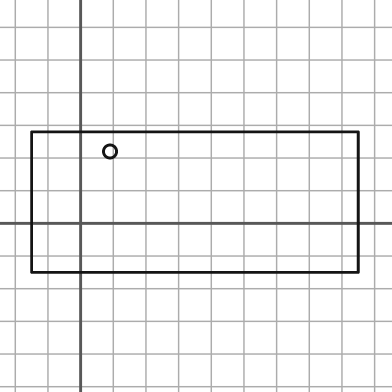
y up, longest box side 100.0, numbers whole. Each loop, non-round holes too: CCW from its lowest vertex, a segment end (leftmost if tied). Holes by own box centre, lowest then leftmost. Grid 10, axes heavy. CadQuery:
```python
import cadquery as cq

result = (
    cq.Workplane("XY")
    .moveTo(-15.0, -15.0)
    .lineTo(85.0, -15.0)
    .lineTo(85.0, 28.0)
    .lineTo(-15.0, 28.0)
    .close()
    .moveTo(9.0, 22.0)
    .circle(2.0)
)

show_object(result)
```